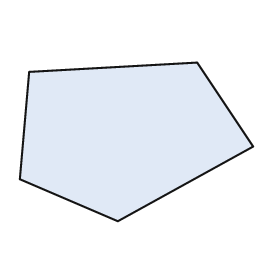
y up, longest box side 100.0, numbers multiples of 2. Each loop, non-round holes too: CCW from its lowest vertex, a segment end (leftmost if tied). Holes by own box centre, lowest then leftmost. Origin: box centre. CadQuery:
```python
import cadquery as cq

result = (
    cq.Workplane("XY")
    .moveTo(-8.0, -34.0)
    .lineTo(50.0, -2.0)
    .lineTo(26.0, 34.0)
    .lineTo(-46.0, 30.0)
    .lineTo(-50.0, -16.0)
    .close()
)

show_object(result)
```